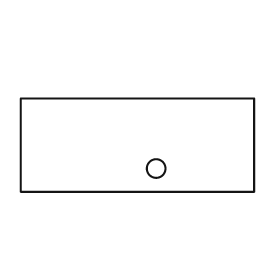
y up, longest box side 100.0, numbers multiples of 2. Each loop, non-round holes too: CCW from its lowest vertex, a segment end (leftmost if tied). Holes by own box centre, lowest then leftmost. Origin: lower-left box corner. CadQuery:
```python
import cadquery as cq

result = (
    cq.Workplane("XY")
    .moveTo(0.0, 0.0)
    .lineTo(100.0, 0.0)
    .lineTo(100.0, 40.0)
    .lineTo(0.0, 40.0)
    .close()
    .moveTo(58.0, 10.0)
    .circle(4.0)
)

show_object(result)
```